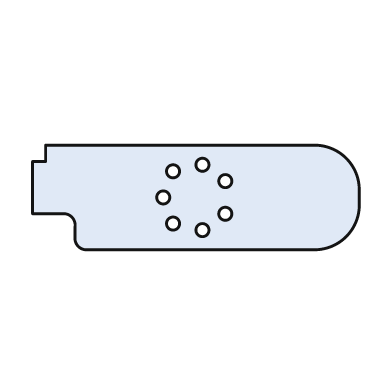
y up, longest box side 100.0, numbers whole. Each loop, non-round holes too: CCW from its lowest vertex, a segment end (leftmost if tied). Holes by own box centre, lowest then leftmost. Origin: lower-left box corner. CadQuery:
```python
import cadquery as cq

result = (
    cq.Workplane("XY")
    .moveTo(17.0, 0.0)
    .lineTo(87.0, 0.0)
    .threePointArc((96.0, 4.0), (100.0, 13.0))
    .lineTo(100.0, 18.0)
    .threePointArc((96.0, 28.0), (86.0, 32.0))
    .lineTo(4.0, 32.0)
    .lineTo(4.0, 27.0)
    .lineTo(0.0, 27.0)
    .lineTo(0.0, 11.0)
    .lineTo(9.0, 11.0)
    .threePointArc((12.0, 10.0), (13.0, 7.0))
    .lineTo(13.0, 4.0)
    .threePointArc((14.0, 1.0), (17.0, 0.0))
    .close()
    .moveTo(52.0, 6.0)
    .circle(2.0)
    .moveTo(43.0, 8.0)
    .circle(2.0)
    .moveTo(59.0, 11.0)
    .circle(2.0)
    .moveTo(40.0, 16.0)
    .circle(2.0)
    .moveTo(59.0, 21.0)
    .circle(2.0)
    .moveTo(43.0, 24.0)
    .circle(2.0)
    .moveTo(52.0, 26.0)
    .circle(2.0)
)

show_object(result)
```